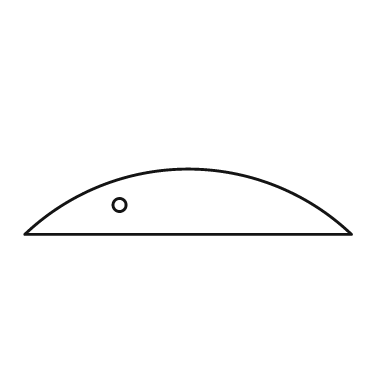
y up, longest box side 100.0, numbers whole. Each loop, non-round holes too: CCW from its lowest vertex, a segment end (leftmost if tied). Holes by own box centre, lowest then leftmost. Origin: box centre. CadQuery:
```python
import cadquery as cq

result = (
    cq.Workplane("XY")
    .moveTo(-50.0, -10.0)
    .lineTo(50.0, -10.0)
    .threePointArc((0.0, 10.0), (-50.0, -10.0))
    .close()
    .moveTo(-21.0, -1.0)
    .circle(2.0)
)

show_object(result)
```